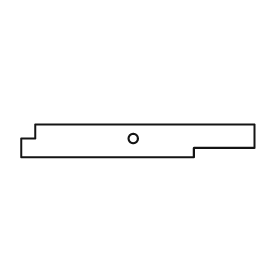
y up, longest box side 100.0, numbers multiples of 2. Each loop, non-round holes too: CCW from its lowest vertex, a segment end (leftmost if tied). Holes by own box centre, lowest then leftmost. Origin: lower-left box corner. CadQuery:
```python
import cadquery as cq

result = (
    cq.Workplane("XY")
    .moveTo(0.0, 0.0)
    .lineTo(74.0, 0.0)
    .lineTo(74.0, 4.0)
    .lineTo(100.0, 4.0)
    .lineTo(100.0, 14.0)
    .lineTo(6.0, 14.0)
    .lineTo(6.0, 8.0)
    .lineTo(0.0, 8.0)
    .close()
    .moveTo(48.0, 8.0)
    .circle(2.0)
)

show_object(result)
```